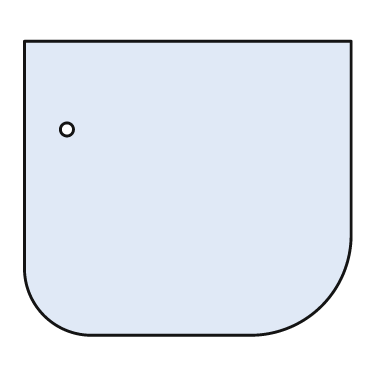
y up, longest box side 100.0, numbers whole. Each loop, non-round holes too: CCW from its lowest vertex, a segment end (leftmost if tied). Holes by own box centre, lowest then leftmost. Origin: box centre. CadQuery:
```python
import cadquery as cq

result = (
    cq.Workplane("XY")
    .moveTo(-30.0, -45.0)
    .lineTo(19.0, -45.0)
    .threePointArc((41.0, -36.0), (50.0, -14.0))
    .lineTo(50.0, 45.0)
    .lineTo(-50.0, 45.0)
    .lineTo(-50.0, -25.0)
    .threePointArc((-44.0, -39.0), (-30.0, -45.0))
    .close()
    .moveTo(-37.0, 18.0)
    .circle(2.0)
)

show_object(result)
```